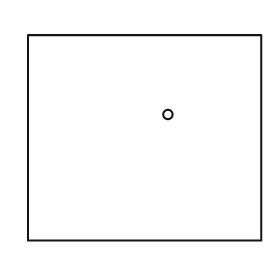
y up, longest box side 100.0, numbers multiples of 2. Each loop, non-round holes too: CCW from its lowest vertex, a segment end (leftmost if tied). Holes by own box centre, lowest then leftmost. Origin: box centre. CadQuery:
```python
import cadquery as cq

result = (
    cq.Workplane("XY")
    .moveTo(-50.0, -44.0)
    .lineTo(50.0, -44.0)
    .lineTo(50.0, 44.0)
    .lineTo(-50.0, 44.0)
    .close()
    .moveTo(10.0, 10.0)
    .circle(2.0)
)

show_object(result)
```